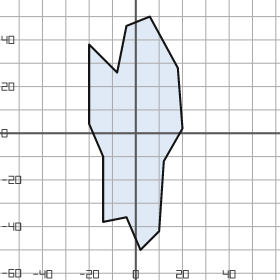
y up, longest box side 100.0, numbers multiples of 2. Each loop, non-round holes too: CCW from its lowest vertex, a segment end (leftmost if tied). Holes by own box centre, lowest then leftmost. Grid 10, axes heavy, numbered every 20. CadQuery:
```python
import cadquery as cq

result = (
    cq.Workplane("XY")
    .moveTo(2.0, -50.0)
    .lineTo(10.0, -42.0)
    .lineTo(12.0, -12.0)
    .lineTo(20.0, 2.0)
    .lineTo(18.0, 28.0)
    .lineTo(6.0, 50.0)
    .lineTo(-4.0, 46.0)
    .lineTo(-8.0, 26.0)
    .lineTo(-20.0, 38.0)
    .lineTo(-20.0, 4.0)
    .lineTo(-14.0, -10.0)
    .lineTo(-14.0, -38.0)
    .lineTo(-4.0, -36.0)
    .close()
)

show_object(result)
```